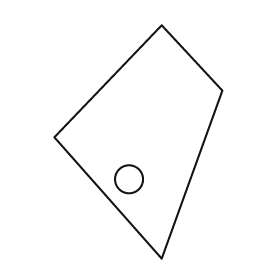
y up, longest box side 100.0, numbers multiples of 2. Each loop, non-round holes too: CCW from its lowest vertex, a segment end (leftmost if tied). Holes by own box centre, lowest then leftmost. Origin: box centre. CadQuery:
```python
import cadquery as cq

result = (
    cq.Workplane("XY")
    .moveTo(10.0, -50.0)
    .lineTo(36.0, 22.0)
    .lineTo(10.0, 50.0)
    .lineTo(-36.0, 2.0)
    .close()
    .moveTo(-4.0, -16.0)
    .circle(6.0)
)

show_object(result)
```